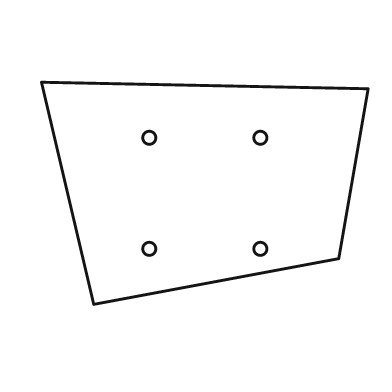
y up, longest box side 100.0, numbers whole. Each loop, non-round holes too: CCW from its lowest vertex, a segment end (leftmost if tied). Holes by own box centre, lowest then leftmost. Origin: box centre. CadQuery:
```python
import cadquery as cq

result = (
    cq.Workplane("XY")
    .moveTo(-34.0, -34.0)
    .lineTo(41.0, -20.0)
    .lineTo(50.0, 32.0)
    .lineTo(-50.0, 34.0)
    .close()
    .moveTo(-17.0, -17.0)
    .circle(2.0)
    .moveTo(17.0, -17.0)
    .circle(2.0)
    .moveTo(-17.0, 17.0)
    .circle(2.0)
    .moveTo(17.0, 17.0)
    .circle(2.0)
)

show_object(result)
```